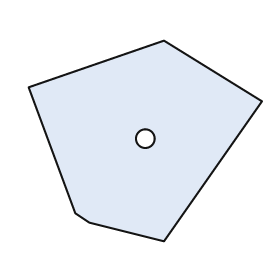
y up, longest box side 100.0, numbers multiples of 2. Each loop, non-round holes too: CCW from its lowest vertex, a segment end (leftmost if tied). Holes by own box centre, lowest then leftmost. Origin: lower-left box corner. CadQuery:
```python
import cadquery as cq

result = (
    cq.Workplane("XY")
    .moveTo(58.0, 0.0)
    .lineTo(100.0, 60.0)
    .lineTo(58.0, 86.0)
    .lineTo(0.0, 66.0)
    .lineTo(20.0, 12.0)
    .lineTo(26.0, 8.0)
    .close()
    .moveTo(50.0, 44.0)
    .circle(4.0)
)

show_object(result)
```